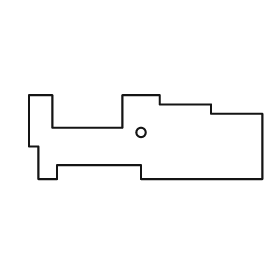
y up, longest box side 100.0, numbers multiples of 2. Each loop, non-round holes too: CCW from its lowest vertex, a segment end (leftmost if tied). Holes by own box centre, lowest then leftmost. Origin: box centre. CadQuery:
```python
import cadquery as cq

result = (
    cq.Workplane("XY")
    .moveTo(-46.0, -18.0)
    .lineTo(-38.0, -18.0)
    .lineTo(-38.0, -12.0)
    .lineTo(-2.0, -12.0)
    .lineTo(-2.0, -18.0)
    .lineTo(50.0, -18.0)
    .lineTo(50.0, 10.0)
    .lineTo(28.0, 10.0)
    .lineTo(28.0, 14.0)
    .lineTo(6.0, 14.0)
    .lineTo(6.0, 18.0)
    .lineTo(-10.0, 18.0)
    .lineTo(-10.0, 4.0)
    .lineTo(-40.0, 4.0)
    .lineTo(-40.0, 18.0)
    .lineTo(-50.0, 18.0)
    .lineTo(-50.0, -4.0)
    .lineTo(-46.0, -4.0)
    .close()
    .moveTo(-2.0, 2.0)
    .circle(2.0)
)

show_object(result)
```